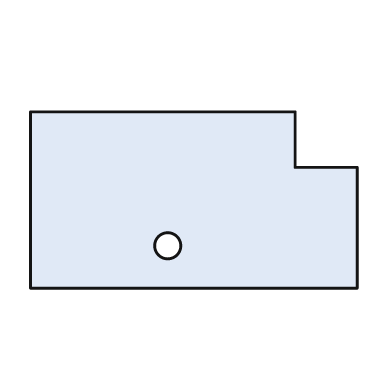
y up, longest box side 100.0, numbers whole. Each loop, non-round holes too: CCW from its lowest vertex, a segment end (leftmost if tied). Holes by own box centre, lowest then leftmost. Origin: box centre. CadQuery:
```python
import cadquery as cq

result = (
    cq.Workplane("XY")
    .moveTo(-50.0, -27.0)
    .lineTo(50.0, -27.0)
    .lineTo(50.0, 10.0)
    .lineTo(31.0, 10.0)
    .lineTo(31.0, 27.0)
    .lineTo(-50.0, 27.0)
    .close()
    .moveTo(-8.0, -14.0)
    .circle(4.0)
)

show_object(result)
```